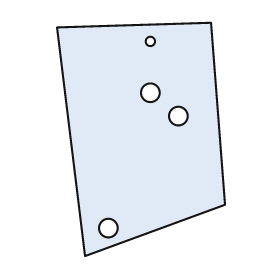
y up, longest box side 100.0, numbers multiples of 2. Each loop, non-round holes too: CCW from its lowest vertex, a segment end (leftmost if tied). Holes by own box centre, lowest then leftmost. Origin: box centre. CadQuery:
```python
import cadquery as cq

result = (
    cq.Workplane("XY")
    .moveTo(-24.0, -50.0)
    .lineTo(36.0, -28.0)
    .lineTo(30.0, 50.0)
    .lineTo(-36.0, 48.0)
    .close()
    .moveTo(-14.0, -38.0)
    .circle(4.0)
    .moveTo(16.0, 10.0)
    .circle(4.0)
    .moveTo(4.0, 20.0)
    .circle(4.0)
    .moveTo(4.0, 42.0)
    .circle(2.0)
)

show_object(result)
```